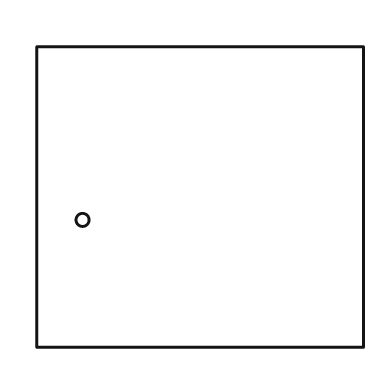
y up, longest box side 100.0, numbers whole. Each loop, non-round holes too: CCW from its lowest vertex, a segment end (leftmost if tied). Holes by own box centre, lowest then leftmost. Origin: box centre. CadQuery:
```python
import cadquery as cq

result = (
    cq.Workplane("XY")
    .moveTo(-50.0, -46.0)
    .lineTo(50.0, -46.0)
    .lineTo(50.0, 46.0)
    .lineTo(-50.0, 46.0)
    .close()
    .moveTo(-36.0, -7.0)
    .circle(2.0)
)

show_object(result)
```